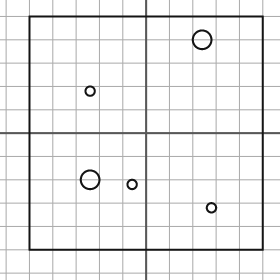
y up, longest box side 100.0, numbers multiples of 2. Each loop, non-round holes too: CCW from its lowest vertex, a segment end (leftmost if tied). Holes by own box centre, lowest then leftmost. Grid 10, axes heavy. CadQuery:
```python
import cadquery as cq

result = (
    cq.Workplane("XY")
    .moveTo(-50.0, -50.0)
    .lineTo(50.0, -50.0)
    .lineTo(50.0, 50.0)
    .lineTo(-50.0, 50.0)
    .close()
    .moveTo(28.0, -32.0)
    .circle(2.0)
    .moveTo(-6.0, -22.0)
    .circle(2.0)
    .moveTo(-24.0, -20.0)
    .circle(4.0)
    .moveTo(-24.0, 18.0)
    .circle(2.0)
    .moveTo(24.0, 40.0)
    .circle(4.0)
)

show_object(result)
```